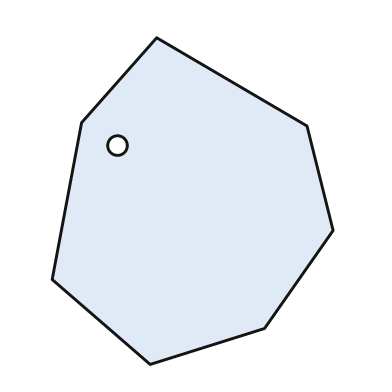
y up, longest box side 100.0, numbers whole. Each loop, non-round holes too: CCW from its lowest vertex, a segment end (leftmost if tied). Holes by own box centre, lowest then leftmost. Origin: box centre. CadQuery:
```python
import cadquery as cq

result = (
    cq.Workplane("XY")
    .moveTo(-13.0, -50.0)
    .lineTo(22.0, -39.0)
    .lineTo(43.0, -9.0)
    .lineTo(35.0, 23.0)
    .lineTo(-11.0, 50.0)
    .lineTo(-34.0, 24.0)
    .lineTo(-43.0, -24.0)
    .close()
    .moveTo(-23.0, 17.0)
    .circle(3.0)
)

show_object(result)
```